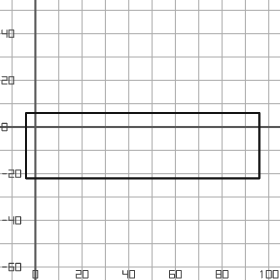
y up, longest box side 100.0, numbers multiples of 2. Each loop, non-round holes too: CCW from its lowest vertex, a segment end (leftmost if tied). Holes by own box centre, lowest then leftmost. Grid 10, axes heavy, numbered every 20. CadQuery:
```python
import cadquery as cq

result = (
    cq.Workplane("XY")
    .moveTo(-4.0, -22.0)
    .lineTo(96.0, -22.0)
    .lineTo(96.0, 6.0)
    .lineTo(-4.0, 6.0)
    .close()
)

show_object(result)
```